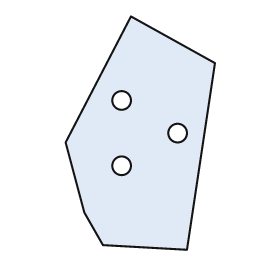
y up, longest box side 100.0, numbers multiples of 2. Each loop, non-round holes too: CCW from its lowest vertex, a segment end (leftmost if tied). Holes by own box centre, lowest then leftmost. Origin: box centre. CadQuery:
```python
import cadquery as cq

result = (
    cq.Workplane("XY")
    .moveTo(20.0, -50.0)
    .lineTo(32.0, 30.0)
    .lineTo(-4.0, 50.0)
    .lineTo(-32.0, -4.0)
    .lineTo(-24.0, -34.0)
    .lineTo(-16.0, -48.0)
    .close()
    .moveTo(-8.0, -14.0)
    .circle(4.0)
    .moveTo(16.0, 0.0)
    .circle(4.0)
    .moveTo(-8.0, 14.0)
    .circle(4.0)
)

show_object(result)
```